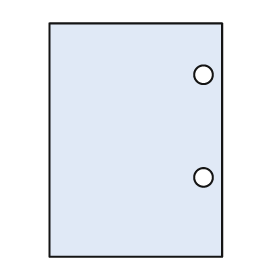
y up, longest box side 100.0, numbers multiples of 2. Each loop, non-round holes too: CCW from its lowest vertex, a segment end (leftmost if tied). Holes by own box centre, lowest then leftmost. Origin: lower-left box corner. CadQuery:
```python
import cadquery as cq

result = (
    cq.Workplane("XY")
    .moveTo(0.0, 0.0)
    .lineTo(74.0, 0.0)
    .lineTo(74.0, 100.0)
    .lineTo(0.0, 100.0)
    .close()
    .moveTo(66.0, 34.0)
    .circle(4.0)
    .moveTo(66.0, 78.0)
    .circle(4.0)
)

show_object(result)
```